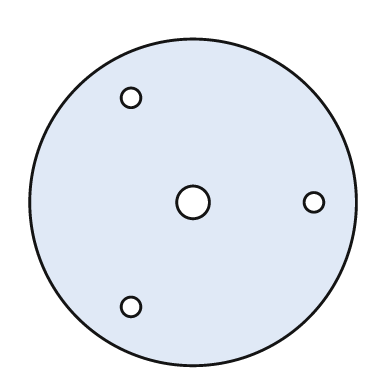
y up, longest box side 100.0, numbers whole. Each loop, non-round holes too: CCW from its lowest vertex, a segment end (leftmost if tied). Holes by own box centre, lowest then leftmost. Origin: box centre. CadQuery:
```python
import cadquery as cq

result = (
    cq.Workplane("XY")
    .moveTo(0.0, 0.0)
    .circle(50.0)
    .moveTo(-19.0, -32.0)
    .circle(3.0)
    .moveTo(0.0, 0.0)
    .circle(5.0)
    .moveTo(37.0, 0.0)
    .circle(3.0)
    .moveTo(-19.0, 32.0)
    .circle(3.0)
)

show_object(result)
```